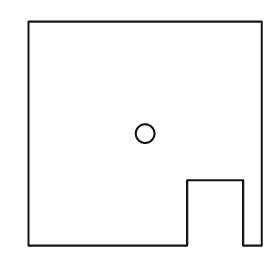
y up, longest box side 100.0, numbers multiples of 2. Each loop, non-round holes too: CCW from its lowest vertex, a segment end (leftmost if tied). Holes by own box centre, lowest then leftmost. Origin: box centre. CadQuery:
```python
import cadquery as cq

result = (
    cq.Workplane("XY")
    .moveTo(-50.0, -48.0)
    .lineTo(18.0, -48.0)
    .lineTo(18.0, -20.0)
    .lineTo(42.0, -20.0)
    .lineTo(42.0, -48.0)
    .lineTo(50.0, -48.0)
    .lineTo(50.0, 48.0)
    .lineTo(-50.0, 48.0)
    .close()
    .moveTo(0.0, 0.0)
    .circle(4.0)
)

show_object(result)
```